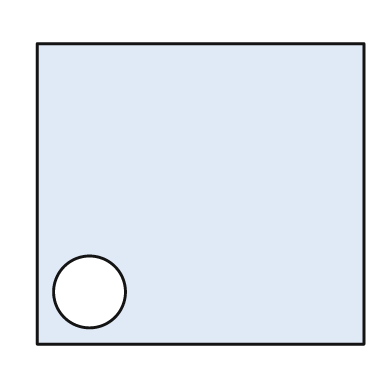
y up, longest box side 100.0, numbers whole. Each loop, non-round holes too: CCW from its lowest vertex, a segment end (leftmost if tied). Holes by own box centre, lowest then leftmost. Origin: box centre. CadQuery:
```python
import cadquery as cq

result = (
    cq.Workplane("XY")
    .moveTo(-50.0, -46.0)
    .lineTo(50.0, -46.0)
    .lineTo(50.0, 46.0)
    .lineTo(-50.0, 46.0)
    .close()
    .moveTo(-34.0, -30.0)
    .circle(11.0)
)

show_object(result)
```